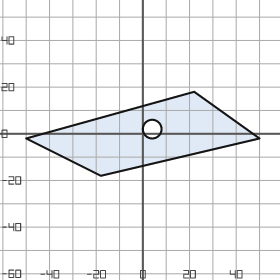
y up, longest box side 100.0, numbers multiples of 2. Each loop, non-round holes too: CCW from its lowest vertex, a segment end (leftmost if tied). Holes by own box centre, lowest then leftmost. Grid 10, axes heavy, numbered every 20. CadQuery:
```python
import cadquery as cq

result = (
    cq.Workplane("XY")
    .moveTo(-18.0, -18.0)
    .lineTo(50.0, -2.0)
    .lineTo(22.0, 18.0)
    .lineTo(-50.0, -2.0)
    .close()
    .moveTo(4.0, 2.0)
    .circle(4.0)
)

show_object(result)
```